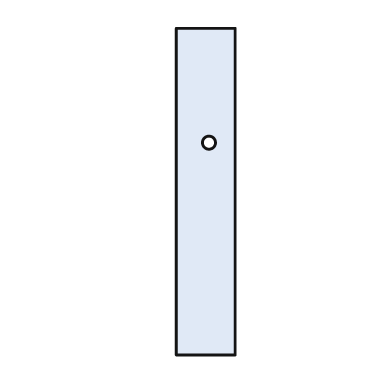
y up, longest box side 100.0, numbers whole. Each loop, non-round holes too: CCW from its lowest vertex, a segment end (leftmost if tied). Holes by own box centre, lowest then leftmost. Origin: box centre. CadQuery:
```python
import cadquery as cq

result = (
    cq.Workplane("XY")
    .moveTo(-9.0, -50.0)
    .lineTo(9.0, -50.0)
    .lineTo(9.0, 50.0)
    .lineTo(-9.0, 50.0)
    .close()
    .moveTo(1.0, 15.0)
    .circle(2.0)
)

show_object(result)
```